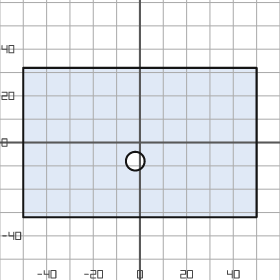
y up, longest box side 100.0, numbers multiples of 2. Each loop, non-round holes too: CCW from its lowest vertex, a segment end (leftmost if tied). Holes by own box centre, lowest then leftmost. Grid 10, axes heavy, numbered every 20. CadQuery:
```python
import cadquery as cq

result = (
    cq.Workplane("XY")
    .moveTo(-50.0, -32.0)
    .lineTo(50.0, -32.0)
    .lineTo(50.0, 32.0)
    .lineTo(-50.0, 32.0)
    .close()
    .moveTo(-2.0, -8.0)
    .circle(4.0)
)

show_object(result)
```